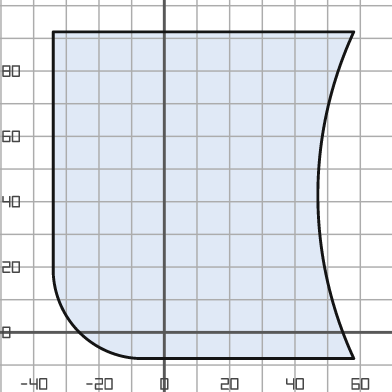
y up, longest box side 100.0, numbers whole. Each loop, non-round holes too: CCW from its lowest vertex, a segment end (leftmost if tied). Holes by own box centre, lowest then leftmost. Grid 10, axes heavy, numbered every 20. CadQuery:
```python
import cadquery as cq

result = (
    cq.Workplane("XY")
    .moveTo(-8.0, -8.0)
    .lineTo(58.0, -8.0)
    .threePointArc((47.0, 42.0), (58.0, 92.0))
    .lineTo(-34.0, 92.0)
    .lineTo(-34.0, 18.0)
    .threePointArc((-26.0, 0.0), (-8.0, -8.0))
    .close()
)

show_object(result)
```